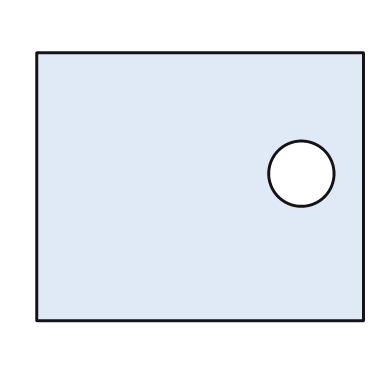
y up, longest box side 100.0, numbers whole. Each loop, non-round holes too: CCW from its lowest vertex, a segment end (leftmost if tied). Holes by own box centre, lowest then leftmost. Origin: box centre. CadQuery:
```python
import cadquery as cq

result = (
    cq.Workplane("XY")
    .moveTo(-50.0, -41.0)
    .lineTo(50.0, -41.0)
    .lineTo(50.0, 41.0)
    .lineTo(-50.0, 41.0)
    .close()
    .moveTo(31.0, 4.0)
    .circle(10.0)
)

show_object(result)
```